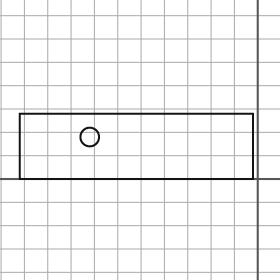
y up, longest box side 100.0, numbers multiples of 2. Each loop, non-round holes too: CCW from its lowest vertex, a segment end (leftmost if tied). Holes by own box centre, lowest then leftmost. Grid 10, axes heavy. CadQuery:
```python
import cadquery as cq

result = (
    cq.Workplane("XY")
    .moveTo(-102.0, 0.0)
    .lineTo(-2.0, 0.0)
    .lineTo(-2.0, 28.0)
    .lineTo(-102.0, 28.0)
    .close()
    .moveTo(-72.0, 18.0)
    .circle(4.0)
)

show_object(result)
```